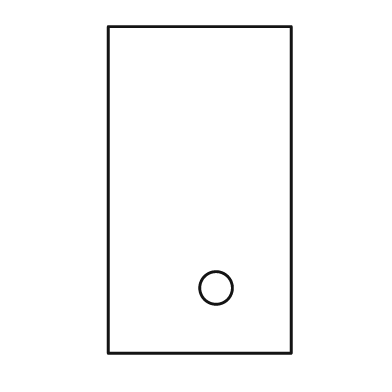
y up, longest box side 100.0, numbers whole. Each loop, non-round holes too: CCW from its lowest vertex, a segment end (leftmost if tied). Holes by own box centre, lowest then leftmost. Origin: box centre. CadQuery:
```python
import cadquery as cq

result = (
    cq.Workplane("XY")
    .moveTo(-28.0, -50.0)
    .lineTo(28.0, -50.0)
    .lineTo(28.0, 50.0)
    .lineTo(-28.0, 50.0)
    .close()
    .moveTo(5.0, -30.0)
    .circle(5.0)
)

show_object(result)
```